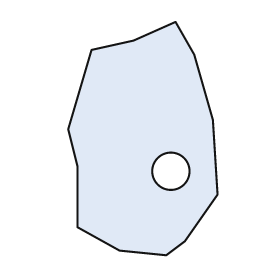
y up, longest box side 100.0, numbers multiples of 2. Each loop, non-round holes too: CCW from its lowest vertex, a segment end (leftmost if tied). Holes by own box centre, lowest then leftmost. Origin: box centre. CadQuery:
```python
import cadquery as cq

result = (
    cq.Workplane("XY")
    .moveTo(10.0, -50.0)
    .lineTo(18.0, -44.0)
    .lineTo(32.0, -24.0)
    .lineTo(30.0, 8.0)
    .lineTo(22.0, 36.0)
    .lineTo(14.0, 50.0)
    .lineTo(-4.0, 42.0)
    .lineTo(-22.0, 38.0)
    .lineTo(-32.0, 4.0)
    .lineTo(-28.0, -12.0)
    .lineTo(-28.0, -38.0)
    .lineTo(-10.0, -48.0)
    .close()
    .moveTo(12.0, -14.0)
    .circle(8.0)
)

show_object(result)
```